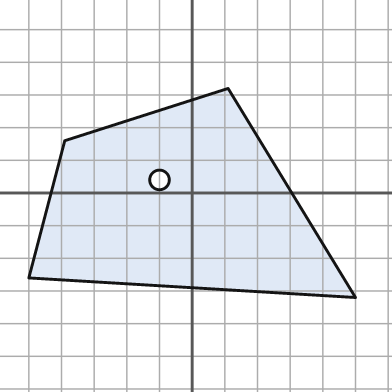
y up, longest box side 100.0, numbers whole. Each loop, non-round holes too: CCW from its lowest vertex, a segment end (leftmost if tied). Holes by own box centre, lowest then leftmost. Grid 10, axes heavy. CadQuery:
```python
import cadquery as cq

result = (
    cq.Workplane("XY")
    .moveTo(50.0, -32.0)
    .lineTo(11.0, 32.0)
    .lineTo(-39.0, 16.0)
    .lineTo(-50.0, -26.0)
    .close()
    .moveTo(-10.0, 4.0)
    .circle(3.0)
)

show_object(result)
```